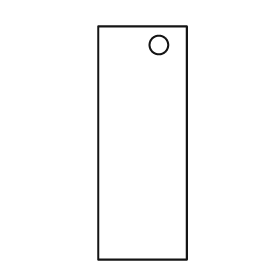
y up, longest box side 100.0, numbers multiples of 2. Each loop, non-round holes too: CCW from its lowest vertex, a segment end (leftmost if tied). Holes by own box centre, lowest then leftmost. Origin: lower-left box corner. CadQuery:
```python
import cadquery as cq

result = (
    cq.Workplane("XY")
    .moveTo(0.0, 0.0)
    .lineTo(38.0, 0.0)
    .lineTo(38.0, 100.0)
    .lineTo(0.0, 100.0)
    .close()
    .moveTo(26.0, 92.0)
    .circle(4.0)
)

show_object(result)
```